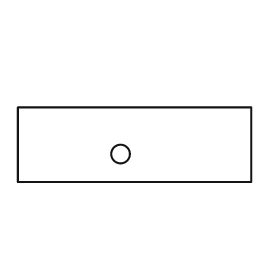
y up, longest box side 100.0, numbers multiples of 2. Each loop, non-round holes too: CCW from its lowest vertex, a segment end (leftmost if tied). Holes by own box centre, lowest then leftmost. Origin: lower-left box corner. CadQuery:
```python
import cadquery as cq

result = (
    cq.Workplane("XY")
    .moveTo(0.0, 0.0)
    .lineTo(100.0, 0.0)
    .lineTo(100.0, 32.0)
    .lineTo(0.0, 32.0)
    .close()
    .moveTo(44.0, 12.0)
    .circle(4.0)
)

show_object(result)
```